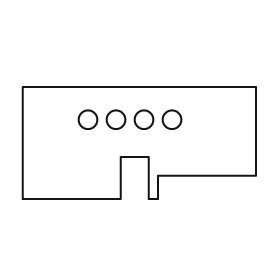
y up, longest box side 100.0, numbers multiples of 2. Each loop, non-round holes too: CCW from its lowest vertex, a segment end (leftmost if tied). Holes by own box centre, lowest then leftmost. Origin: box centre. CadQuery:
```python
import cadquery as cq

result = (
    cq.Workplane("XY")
    .moveTo(-50.0, -24.0)
    .lineTo(-8.0, -24.0)
    .lineTo(-8.0, -6.0)
    .lineTo(4.0, -6.0)
    .lineTo(4.0, -24.0)
    .lineTo(8.0, -24.0)
    .lineTo(8.0, -14.0)
    .lineTo(50.0, -14.0)
    .lineTo(50.0, 24.0)
    .lineTo(-50.0, 24.0)
    .close()
    .moveTo(-22.0, 10.0)
    .circle(4.0)
    .moveTo(-10.0, 10.0)
    .circle(4.0)
    .moveTo(2.0, 10.0)
    .circle(4.0)
    .moveTo(14.0, 10.0)
    .circle(4.0)
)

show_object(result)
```